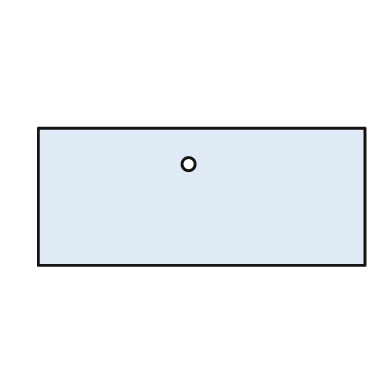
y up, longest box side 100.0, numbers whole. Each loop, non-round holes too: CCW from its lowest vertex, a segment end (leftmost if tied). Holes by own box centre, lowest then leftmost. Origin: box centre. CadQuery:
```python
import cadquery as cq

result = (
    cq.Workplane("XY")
    .moveTo(-50.0, -21.0)
    .lineTo(50.0, -21.0)
    .lineTo(50.0, 21.0)
    .lineTo(-50.0, 21.0)
    .close()
    .moveTo(-4.0, 10.0)
    .circle(2.0)
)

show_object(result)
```